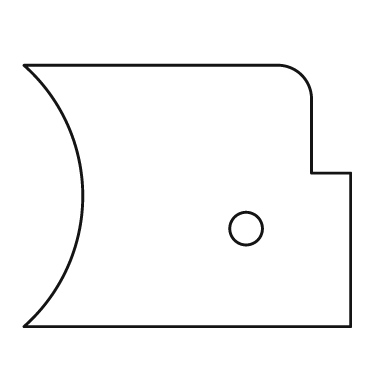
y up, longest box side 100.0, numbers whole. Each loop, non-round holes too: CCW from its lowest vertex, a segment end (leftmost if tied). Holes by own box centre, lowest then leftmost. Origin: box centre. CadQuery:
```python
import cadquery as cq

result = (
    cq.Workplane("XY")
    .moveTo(-50.0, -40.0)
    .lineTo(50.0, -40.0)
    .lineTo(50.0, 7.0)
    .lineTo(38.0, 7.0)
    .lineTo(38.0, 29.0)
    .threePointArc((35.0, 37.0), (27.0, 40.0))
    .lineTo(-50.0, 40.0)
    .threePointArc((-32.0, 0.0), (-50.0, -40.0))
    .close()
    .moveTo(18.0, -10.0)
    .circle(5.0)
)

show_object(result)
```